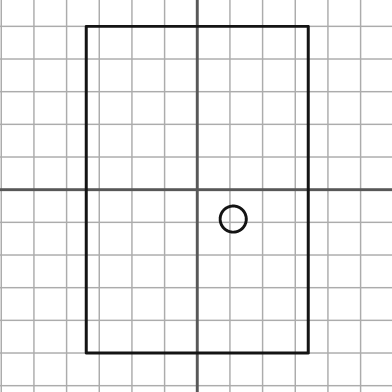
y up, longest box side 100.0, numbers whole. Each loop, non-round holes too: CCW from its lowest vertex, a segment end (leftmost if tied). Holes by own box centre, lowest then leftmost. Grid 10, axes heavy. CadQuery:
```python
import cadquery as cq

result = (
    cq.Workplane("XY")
    .moveTo(-34.0, -50.0)
    .lineTo(34.0, -50.0)
    .lineTo(34.0, 50.0)
    .lineTo(-34.0, 50.0)
    .close()
    .moveTo(11.0, -9.0)
    .circle(4.0)
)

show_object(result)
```